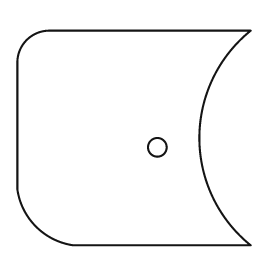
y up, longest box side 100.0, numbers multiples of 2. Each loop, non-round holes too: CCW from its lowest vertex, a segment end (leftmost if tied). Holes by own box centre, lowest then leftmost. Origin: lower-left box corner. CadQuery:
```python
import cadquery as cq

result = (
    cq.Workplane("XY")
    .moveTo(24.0, 0.0)
    .lineTo(100.0, 0.0)
    .threePointArc((78.0, 46.0), (100.0, 92.0))
    .lineTo(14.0, 92.0)
    .threePointArc((4.0, 88.0), (0.0, 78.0))
    .lineTo(0.0, 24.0)
    .threePointArc((8.0, 8.0), (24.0, 0.0))
    .close()
    .moveTo(60.0, 42.0)
    .circle(4.0)
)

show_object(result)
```